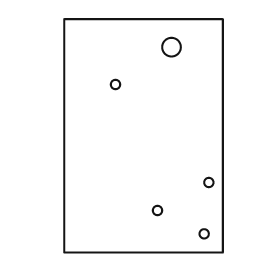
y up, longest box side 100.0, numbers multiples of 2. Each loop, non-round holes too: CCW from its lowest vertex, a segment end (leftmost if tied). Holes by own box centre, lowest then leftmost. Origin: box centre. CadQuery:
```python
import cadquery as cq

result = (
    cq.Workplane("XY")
    .moveTo(-34.0, -50.0)
    .lineTo(34.0, -50.0)
    .lineTo(34.0, 50.0)
    .lineTo(-34.0, 50.0)
    .close()
    .moveTo(26.0, -42.0)
    .circle(2.0)
    .moveTo(6.0, -32.0)
    .circle(2.0)
    .moveTo(28.0, -20.0)
    .circle(2.0)
    .moveTo(-12.0, 22.0)
    .circle(2.0)
    .moveTo(12.0, 38.0)
    .circle(4.0)
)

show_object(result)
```